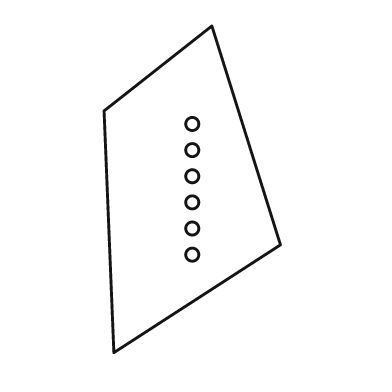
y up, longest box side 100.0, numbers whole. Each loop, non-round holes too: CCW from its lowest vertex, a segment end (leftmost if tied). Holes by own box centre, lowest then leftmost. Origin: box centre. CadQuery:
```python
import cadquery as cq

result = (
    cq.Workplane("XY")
    .moveTo(-24.0, -50.0)
    .lineTo(27.0, -17.0)
    .lineTo(6.0, 50.0)
    .lineTo(-27.0, 24.0)
    .close()
    .moveTo(0.0, -20.0)
    .circle(2.0)
    .moveTo(0.0, -12.0)
    .circle(2.0)
    .moveTo(0.0, -4.0)
    .circle(2.0)
    .moveTo(0.0, 4.0)
    .circle(2.0)
    .moveTo(0.0, 12.0)
    .circle(2.0)
    .moveTo(0.0, 20.0)
    .circle(2.0)
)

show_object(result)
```